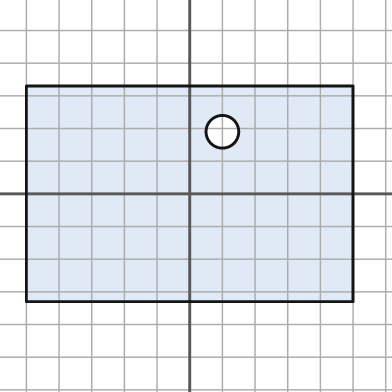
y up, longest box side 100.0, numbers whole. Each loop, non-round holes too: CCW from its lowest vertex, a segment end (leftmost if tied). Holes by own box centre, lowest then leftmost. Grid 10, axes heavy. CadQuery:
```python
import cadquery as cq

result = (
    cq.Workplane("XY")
    .moveTo(-50.0, -33.0)
    .lineTo(50.0, -33.0)
    .lineTo(50.0, 33.0)
    .lineTo(-50.0, 33.0)
    .close()
    .moveTo(10.0, 19.0)
    .circle(5.0)
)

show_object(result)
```